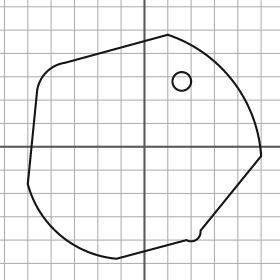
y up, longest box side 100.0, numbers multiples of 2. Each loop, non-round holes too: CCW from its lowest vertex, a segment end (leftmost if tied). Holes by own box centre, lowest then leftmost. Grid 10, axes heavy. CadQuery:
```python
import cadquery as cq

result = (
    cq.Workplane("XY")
    .moveTo(-12.0, -48.0)
    .lineTo(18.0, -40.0)
    .threePointArc((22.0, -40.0), (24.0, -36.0))
    .lineTo(50.0, -4.0)
    .threePointArc((38.0, 28.0), (10.0, 48.0))
    .lineTo(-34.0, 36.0)
    .threePointArc((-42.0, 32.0), (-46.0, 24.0))
    .lineTo(-50.0, -16.0)
    .threePointArc((-36.0, -38.0), (-12.0, -48.0))
    .close()
    .moveTo(16.0, 28.0)
    .circle(4.0)
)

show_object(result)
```